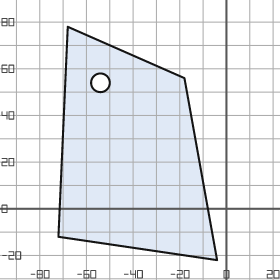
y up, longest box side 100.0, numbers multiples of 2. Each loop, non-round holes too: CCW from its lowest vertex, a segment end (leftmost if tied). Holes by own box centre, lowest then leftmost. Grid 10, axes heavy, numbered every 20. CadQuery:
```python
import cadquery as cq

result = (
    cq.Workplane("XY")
    .moveTo(-4.0, -22.0)
    .lineTo(-18.0, 56.0)
    .lineTo(-68.0, 78.0)
    .lineTo(-72.0, -12.0)
    .close()
    .moveTo(-54.0, 54.0)
    .circle(4.0)
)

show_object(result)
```